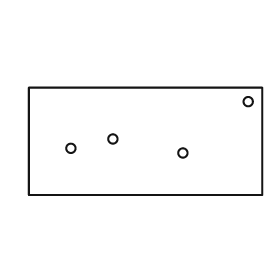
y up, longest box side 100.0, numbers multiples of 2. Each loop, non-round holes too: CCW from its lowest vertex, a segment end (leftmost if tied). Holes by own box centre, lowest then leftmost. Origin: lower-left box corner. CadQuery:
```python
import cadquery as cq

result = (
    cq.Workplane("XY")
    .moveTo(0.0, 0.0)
    .lineTo(100.0, 0.0)
    .lineTo(100.0, 46.0)
    .lineTo(0.0, 46.0)
    .close()
    .moveTo(66.0, 18.0)
    .circle(2.0)
    .moveTo(18.0, 20.0)
    .circle(2.0)
    .moveTo(36.0, 24.0)
    .circle(2.0)
    .moveTo(94.0, 40.0)
    .circle(2.0)
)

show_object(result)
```